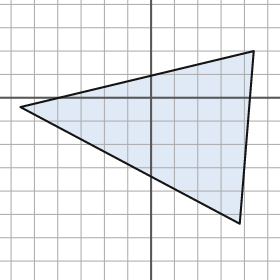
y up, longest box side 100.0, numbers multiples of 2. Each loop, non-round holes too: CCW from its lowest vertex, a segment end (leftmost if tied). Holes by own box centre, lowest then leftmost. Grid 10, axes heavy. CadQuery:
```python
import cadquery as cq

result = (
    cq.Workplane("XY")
    .moveTo(38.0, -54.0)
    .lineTo(44.0, 20.0)
    .lineTo(-56.0, -4.0)
    .close()
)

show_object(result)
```